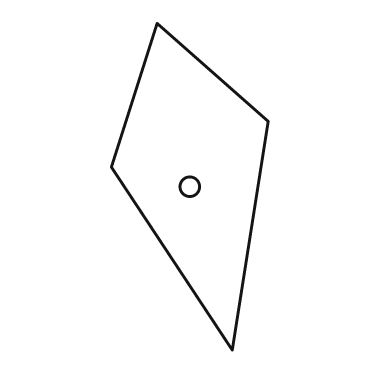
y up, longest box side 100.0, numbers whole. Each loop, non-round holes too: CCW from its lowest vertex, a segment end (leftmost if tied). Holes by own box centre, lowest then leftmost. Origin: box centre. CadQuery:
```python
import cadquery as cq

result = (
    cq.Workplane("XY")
    .moveTo(13.0, -50.0)
    .lineTo(24.0, 20.0)
    .lineTo(-10.0, 50.0)
    .lineTo(-24.0, 6.0)
    .close()
    .moveTo(0.0, 0.0)
    .circle(3.0)
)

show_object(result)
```